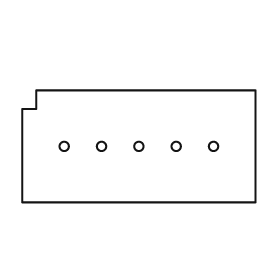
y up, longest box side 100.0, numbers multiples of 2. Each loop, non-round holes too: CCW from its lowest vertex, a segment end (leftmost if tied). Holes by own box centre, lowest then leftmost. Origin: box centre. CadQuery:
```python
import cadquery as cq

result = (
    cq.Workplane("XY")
    .moveTo(-50.0, -24.0)
    .lineTo(50.0, -24.0)
    .lineTo(50.0, 24.0)
    .lineTo(-44.0, 24.0)
    .lineTo(-44.0, 16.0)
    .lineTo(-50.0, 16.0)
    .close()
    .moveTo(-32.0, 0.0)
    .circle(2.0)
    .moveTo(-16.0, 0.0)
    .circle(2.0)
    .moveTo(0.0, 0.0)
    .circle(2.0)
    .moveTo(16.0, 0.0)
    .circle(2.0)
    .moveTo(32.0, 0.0)
    .circle(2.0)
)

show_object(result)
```